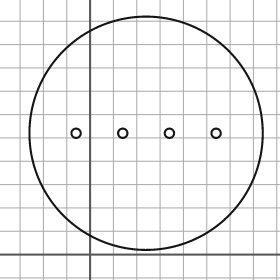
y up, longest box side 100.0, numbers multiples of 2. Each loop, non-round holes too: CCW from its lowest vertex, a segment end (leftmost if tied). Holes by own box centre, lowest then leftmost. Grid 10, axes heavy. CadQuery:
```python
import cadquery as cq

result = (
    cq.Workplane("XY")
    .moveTo(24.0, 52.0)
    .circle(50.0)
    .moveTo(-6.0, 52.0)
    .circle(2.0)
    .moveTo(14.0, 52.0)
    .circle(2.0)
    .moveTo(34.0, 52.0)
    .circle(2.0)
    .moveTo(54.0, 52.0)
    .circle(2.0)
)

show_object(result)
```